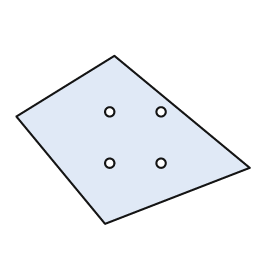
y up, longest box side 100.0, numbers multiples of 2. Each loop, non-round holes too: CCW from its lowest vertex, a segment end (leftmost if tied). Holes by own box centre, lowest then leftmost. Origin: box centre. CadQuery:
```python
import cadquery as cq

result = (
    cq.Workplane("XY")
    .moveTo(-12.0, -36.0)
    .lineTo(50.0, -12.0)
    .lineTo(-8.0, 36.0)
    .lineTo(-50.0, 10.0)
    .close()
    .moveTo(-10.0, -10.0)
    .circle(2.0)
    .moveTo(12.0, -10.0)
    .circle(2.0)
    .moveTo(-10.0, 12.0)
    .circle(2.0)
    .moveTo(12.0, 12.0)
    .circle(2.0)
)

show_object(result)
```